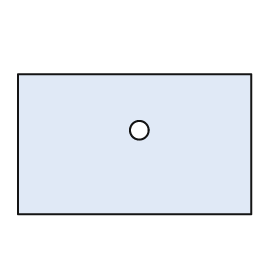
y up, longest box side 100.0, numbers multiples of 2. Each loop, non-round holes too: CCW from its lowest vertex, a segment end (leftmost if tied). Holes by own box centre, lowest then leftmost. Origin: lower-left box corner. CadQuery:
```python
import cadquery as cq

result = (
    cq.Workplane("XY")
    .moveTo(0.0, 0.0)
    .lineTo(100.0, 0.0)
    .lineTo(100.0, 60.0)
    .lineTo(0.0, 60.0)
    .close()
    .moveTo(52.0, 36.0)
    .circle(4.0)
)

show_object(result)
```